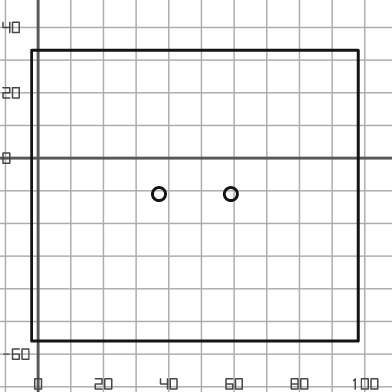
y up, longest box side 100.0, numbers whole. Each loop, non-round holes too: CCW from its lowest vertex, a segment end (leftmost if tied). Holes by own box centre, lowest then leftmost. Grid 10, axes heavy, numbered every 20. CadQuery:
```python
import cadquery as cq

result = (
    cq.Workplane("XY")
    .moveTo(-2.0, -56.0)
    .lineTo(98.0, -56.0)
    .lineTo(98.0, 33.0)
    .lineTo(-2.0, 33.0)
    .close()
    .moveTo(37.0, -11.0)
    .circle(2.0)
    .moveTo(59.0, -11.0)
    .circle(2.0)
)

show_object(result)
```